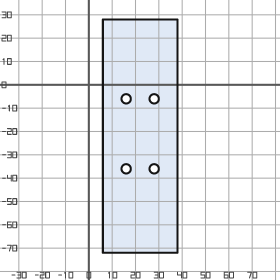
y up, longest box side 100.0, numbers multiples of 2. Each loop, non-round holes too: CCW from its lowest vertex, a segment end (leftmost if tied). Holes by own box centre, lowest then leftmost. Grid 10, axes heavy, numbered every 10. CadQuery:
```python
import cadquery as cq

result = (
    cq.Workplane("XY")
    .moveTo(6.0, -72.0)
    .lineTo(38.0, -72.0)
    .lineTo(38.0, 28.0)
    .lineTo(6.0, 28.0)
    .close()
    .moveTo(16.0, -36.0)
    .circle(2.0)
    .moveTo(28.0, -36.0)
    .circle(2.0)
    .moveTo(16.0, -6.0)
    .circle(2.0)
    .moveTo(28.0, -6.0)
    .circle(2.0)
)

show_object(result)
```